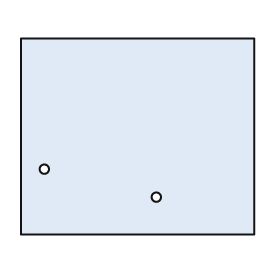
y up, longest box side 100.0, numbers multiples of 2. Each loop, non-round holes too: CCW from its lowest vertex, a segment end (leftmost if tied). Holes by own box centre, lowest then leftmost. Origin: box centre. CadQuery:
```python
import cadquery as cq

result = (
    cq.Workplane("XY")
    .moveTo(-50.0, -42.0)
    .lineTo(50.0, -42.0)
    .lineTo(50.0, 42.0)
    .lineTo(-50.0, 42.0)
    .close()
    .moveTo(8.0, -26.0)
    .circle(2.0)
    .moveTo(-40.0, -14.0)
    .circle(2.0)
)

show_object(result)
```